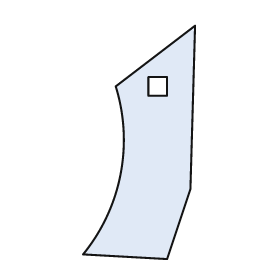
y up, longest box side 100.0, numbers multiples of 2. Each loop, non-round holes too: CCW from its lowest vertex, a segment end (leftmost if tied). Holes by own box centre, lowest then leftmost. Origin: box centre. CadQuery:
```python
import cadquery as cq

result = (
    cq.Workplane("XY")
    .moveTo(12.0, -50.0)
    .lineTo(22.0, -20.0)
    .lineTo(24.0, 50.0)
    .lineTo(-10.0, 24.0)
    .threePointArc((-8.0, -14.0), (-24.0, -48.0))
    .close()
    .moveTo(4.0, 20.0)
    .lineTo(12.0, 20.0)
    .lineTo(12.0, 28.0)
    .lineTo(4.0, 28.0)
    .close()
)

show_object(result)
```